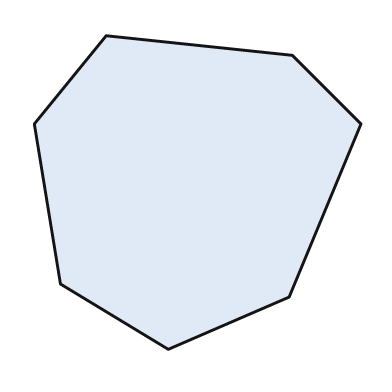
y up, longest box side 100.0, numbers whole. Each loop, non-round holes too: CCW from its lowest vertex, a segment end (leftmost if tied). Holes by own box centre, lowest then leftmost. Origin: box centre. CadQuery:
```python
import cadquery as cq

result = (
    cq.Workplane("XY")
    .moveTo(-9.0, -48.0)
    .lineTo(28.0, -32.0)
    .lineTo(50.0, 21.0)
    .lineTo(29.0, 42.0)
    .lineTo(-28.0, 48.0)
    .lineTo(-50.0, 21.0)
    .lineTo(-42.0, -28.0)
    .close()
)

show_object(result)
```